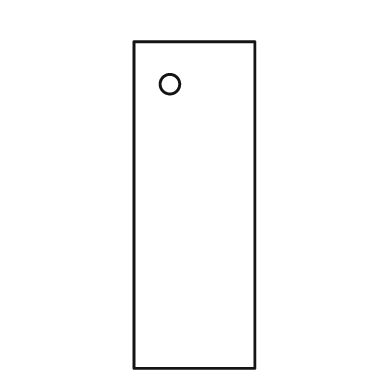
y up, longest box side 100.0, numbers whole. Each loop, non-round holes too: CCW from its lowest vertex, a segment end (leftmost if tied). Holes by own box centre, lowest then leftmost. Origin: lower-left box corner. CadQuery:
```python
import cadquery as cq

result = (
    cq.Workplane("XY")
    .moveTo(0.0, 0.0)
    .lineTo(37.0, 0.0)
    .lineTo(37.0, 100.0)
    .lineTo(0.0, 100.0)
    .close()
    .moveTo(11.0, 87.0)
    .circle(3.0)
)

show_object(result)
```